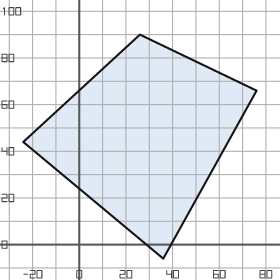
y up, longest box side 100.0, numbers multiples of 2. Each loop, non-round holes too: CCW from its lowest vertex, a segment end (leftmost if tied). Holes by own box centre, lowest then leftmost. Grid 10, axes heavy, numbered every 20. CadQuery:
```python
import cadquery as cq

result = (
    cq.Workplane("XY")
    .moveTo(36.0, -6.0)
    .lineTo(76.0, 66.0)
    .lineTo(26.0, 90.0)
    .lineTo(-24.0, 44.0)
    .close()
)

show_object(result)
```